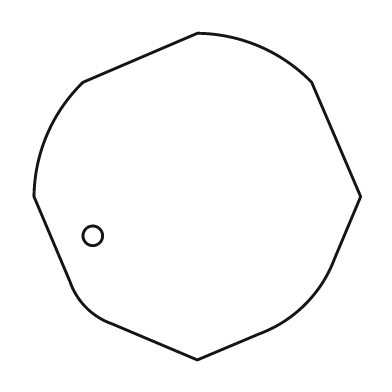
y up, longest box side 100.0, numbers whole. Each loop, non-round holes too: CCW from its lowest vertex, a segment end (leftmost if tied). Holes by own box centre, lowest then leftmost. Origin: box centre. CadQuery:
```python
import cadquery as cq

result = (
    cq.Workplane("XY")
    .moveTo(0.0, -50.0)
    .lineTo(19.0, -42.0)
    .threePointArc((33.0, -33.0), (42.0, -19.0))
    .lineTo(50.0, 0.0)
    .lineTo(35.0, 35.0)
    .threePointArc((19.0, 46.0), (0.0, 50.0))
    .lineTo(-35.0, 35.0)
    .threePointArc((-46.0, 19.0), (-50.0, 0.0))
    .lineTo(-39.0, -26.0)
    .threePointArc((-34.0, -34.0), (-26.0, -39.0))
    .close()
    .moveTo(-32.0, -12.0)
    .circle(3.0)
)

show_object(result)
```